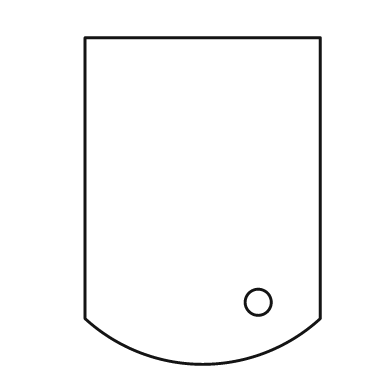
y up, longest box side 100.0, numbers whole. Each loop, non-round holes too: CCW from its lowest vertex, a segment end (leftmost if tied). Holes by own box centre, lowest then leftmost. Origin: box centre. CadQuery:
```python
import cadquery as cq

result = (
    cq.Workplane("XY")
    .moveTo(-36.0, -36.0)
    .threePointArc((0.0, -50.0), (36.0, -36.0))
    .lineTo(36.0, 50.0)
    .lineTo(-36.0, 50.0)
    .close()
    .moveTo(17.0, -31.0)
    .circle(4.0)
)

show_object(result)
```